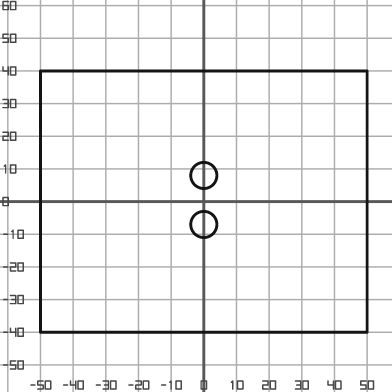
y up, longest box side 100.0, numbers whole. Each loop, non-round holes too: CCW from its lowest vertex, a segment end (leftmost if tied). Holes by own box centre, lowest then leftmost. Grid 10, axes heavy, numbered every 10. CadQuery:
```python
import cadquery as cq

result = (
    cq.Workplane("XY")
    .moveTo(-50.0, -40.0)
    .lineTo(50.0, -40.0)
    .lineTo(50.0, 40.0)
    .lineTo(-50.0, 40.0)
    .close()
    .moveTo(0.0, -7.0)
    .circle(4.0)
    .moveTo(0.0, 8.0)
    .circle(4.0)
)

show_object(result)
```